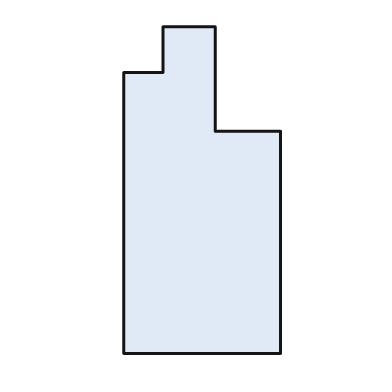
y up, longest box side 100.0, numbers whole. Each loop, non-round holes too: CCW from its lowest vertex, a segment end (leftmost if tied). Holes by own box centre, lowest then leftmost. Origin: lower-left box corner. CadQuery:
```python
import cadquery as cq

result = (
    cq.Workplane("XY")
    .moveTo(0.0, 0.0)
    .lineTo(48.0, 0.0)
    .lineTo(48.0, 68.0)
    .lineTo(28.0, 68.0)
    .lineTo(28.0, 100.0)
    .lineTo(12.0, 100.0)
    .lineTo(12.0, 86.0)
    .lineTo(0.0, 86.0)
    .close()
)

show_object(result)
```